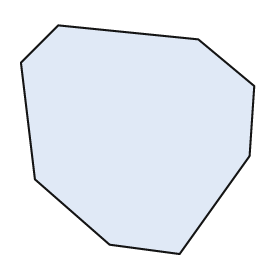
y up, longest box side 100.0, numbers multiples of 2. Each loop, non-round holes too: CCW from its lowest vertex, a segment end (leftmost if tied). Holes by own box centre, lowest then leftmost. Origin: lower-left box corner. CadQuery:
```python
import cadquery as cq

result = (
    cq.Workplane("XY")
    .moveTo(68.0, 0.0)
    .lineTo(98.0, 42.0)
    .lineTo(100.0, 72.0)
    .lineTo(76.0, 92.0)
    .lineTo(16.0, 98.0)
    .lineTo(0.0, 82.0)
    .lineTo(6.0, 32.0)
    .lineTo(38.0, 4.0)
    .close()
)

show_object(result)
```